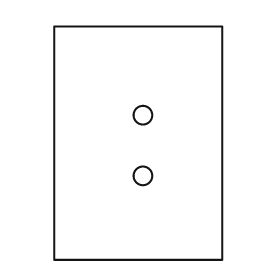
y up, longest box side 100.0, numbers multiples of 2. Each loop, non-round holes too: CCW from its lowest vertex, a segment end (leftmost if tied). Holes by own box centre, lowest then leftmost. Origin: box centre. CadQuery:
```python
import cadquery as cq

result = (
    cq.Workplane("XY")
    .moveTo(-36.0, -50.0)
    .lineTo(36.0, -50.0)
    .lineTo(36.0, 50.0)
    .lineTo(-36.0, 50.0)
    .close()
    .moveTo(2.0, -14.0)
    .circle(4.0)
    .moveTo(2.0, 12.0)
    .circle(4.0)
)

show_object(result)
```